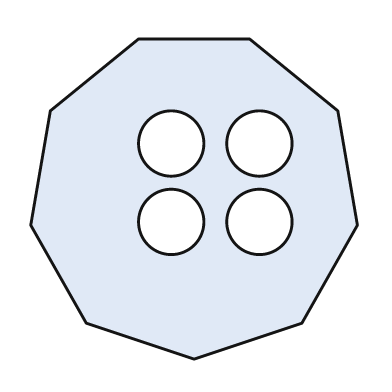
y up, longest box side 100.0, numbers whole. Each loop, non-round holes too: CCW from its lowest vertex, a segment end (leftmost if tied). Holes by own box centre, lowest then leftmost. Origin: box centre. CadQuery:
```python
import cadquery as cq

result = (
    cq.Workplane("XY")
    .moveTo(0.0, -49.0)
    .lineTo(33.0, -38.0)
    .lineTo(50.0, -8.0)
    .lineTo(44.0, 27.0)
    .lineTo(17.0, 49.0)
    .lineTo(-17.0, 49.0)
    .lineTo(-44.0, 27.0)
    .lineTo(-50.0, -8.0)
    .lineTo(-33.0, -38.0)
    .close()
    .moveTo(-7.0, -7.0)
    .circle(10.0)
    .moveTo(20.0, -7.0)
    .circle(10.0)
    .moveTo(-7.0, 17.0)
    .circle(10.0)
    .moveTo(20.0, 17.0)
    .circle(10.0)
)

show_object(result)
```